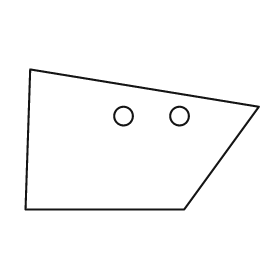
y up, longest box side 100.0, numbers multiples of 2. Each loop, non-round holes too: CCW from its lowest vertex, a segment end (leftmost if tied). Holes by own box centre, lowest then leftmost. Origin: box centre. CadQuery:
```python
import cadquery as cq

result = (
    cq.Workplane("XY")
    .moveTo(-50.0, -30.0)
    .lineTo(18.0, -30.0)
    .lineTo(50.0, 14.0)
    .lineTo(-48.0, 30.0)
    .close()
    .moveTo(-8.0, 10.0)
    .circle(4.0)
    .moveTo(16.0, 10.0)
    .circle(4.0)
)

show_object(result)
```